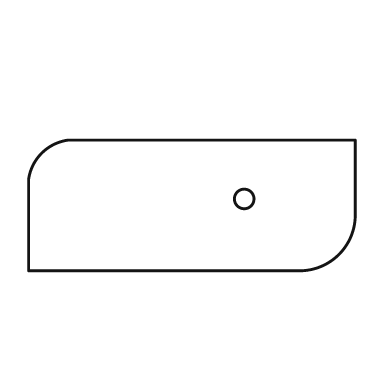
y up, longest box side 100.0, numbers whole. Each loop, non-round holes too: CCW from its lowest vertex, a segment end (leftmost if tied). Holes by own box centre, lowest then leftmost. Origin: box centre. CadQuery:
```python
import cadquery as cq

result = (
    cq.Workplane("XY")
    .moveTo(-50.0, -20.0)
    .lineTo(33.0, -20.0)
    .threePointArc((45.0, -15.0), (50.0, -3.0))
    .lineTo(50.0, 20.0)
    .lineTo(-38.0, 20.0)
    .threePointArc((-46.0, 16.0), (-50.0, 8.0))
    .close()
    .moveTo(16.0, 2.0)
    .circle(3.0)
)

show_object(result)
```